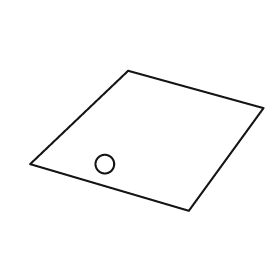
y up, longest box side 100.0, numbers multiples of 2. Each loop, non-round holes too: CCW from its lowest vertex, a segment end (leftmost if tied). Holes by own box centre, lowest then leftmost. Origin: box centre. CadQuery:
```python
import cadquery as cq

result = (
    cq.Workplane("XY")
    .moveTo(18.0, -30.0)
    .lineTo(50.0, 14.0)
    .lineTo(-8.0, 30.0)
    .lineTo(-50.0, -10.0)
    .close()
    .moveTo(-18.0, -10.0)
    .circle(4.0)
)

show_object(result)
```